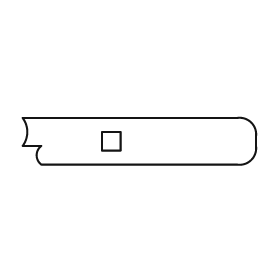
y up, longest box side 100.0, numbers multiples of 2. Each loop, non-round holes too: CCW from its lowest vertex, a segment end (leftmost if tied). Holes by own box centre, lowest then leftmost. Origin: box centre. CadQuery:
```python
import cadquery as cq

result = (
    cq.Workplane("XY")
    .moveTo(-42.0, -10.0)
    .lineTo(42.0, -10.0)
    .threePointArc((48.0, -8.0), (50.0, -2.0))
    .lineTo(50.0, 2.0)
    .threePointArc((48.0, 8.0), (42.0, 10.0))
    .lineTo(-50.0, 10.0)
    .threePointArc((-48.0, 4.0), (-50.0, -2.0))
    .lineTo(-42.0, -2.0)
    .threePointArc((-44.0, -6.0), (-42.0, -10.0))
    .close()
    .moveTo(-16.0, -4.0)
    .lineTo(-8.0, -4.0)
    .lineTo(-8.0, 4.0)
    .lineTo(-16.0, 4.0)
    .close()
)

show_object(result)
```